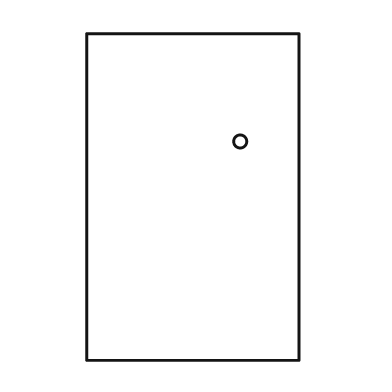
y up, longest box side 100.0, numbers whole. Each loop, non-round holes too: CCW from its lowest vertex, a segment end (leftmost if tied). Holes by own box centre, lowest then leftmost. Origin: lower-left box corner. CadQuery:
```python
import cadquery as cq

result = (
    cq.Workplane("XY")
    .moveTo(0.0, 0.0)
    .lineTo(65.0, 0.0)
    .lineTo(65.0, 100.0)
    .lineTo(0.0, 100.0)
    .close()
    .moveTo(47.0, 67.0)
    .circle(2.0)
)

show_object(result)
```